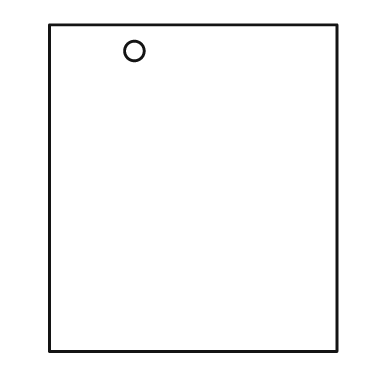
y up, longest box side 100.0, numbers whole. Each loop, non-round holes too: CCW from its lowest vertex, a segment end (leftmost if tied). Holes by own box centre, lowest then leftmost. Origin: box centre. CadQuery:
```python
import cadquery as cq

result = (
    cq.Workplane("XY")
    .moveTo(-44.0, -50.0)
    .lineTo(44.0, -50.0)
    .lineTo(44.0, 50.0)
    .lineTo(-44.0, 50.0)
    .close()
    .moveTo(-18.0, 42.0)
    .circle(3.0)
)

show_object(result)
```